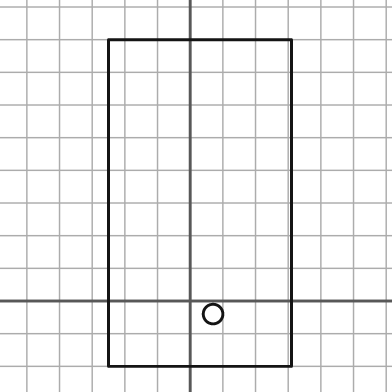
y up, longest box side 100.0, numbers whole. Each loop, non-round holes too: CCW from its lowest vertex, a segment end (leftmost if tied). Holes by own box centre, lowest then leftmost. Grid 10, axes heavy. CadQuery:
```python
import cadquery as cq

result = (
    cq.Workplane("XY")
    .moveTo(-25.0, -20.0)
    .lineTo(31.0, -20.0)
    .lineTo(31.0, 80.0)
    .lineTo(-25.0, 80.0)
    .close()
    .moveTo(7.0, -4.0)
    .circle(3.0)
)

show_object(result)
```